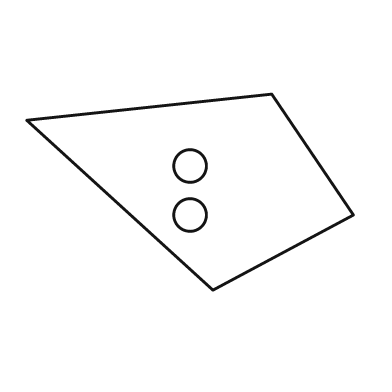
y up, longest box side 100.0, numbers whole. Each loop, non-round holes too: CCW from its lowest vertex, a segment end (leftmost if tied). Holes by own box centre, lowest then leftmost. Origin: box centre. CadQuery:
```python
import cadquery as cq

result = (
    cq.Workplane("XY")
    .moveTo(7.0, -30.0)
    .lineTo(50.0, -7.0)
    .lineTo(25.0, 30.0)
    .lineTo(-50.0, 22.0)
    .close()
    .moveTo(0.0, -7.0)
    .circle(5.0)
    .moveTo(0.0, 8.0)
    .circle(5.0)
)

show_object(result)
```